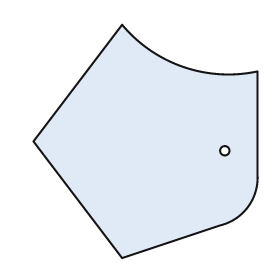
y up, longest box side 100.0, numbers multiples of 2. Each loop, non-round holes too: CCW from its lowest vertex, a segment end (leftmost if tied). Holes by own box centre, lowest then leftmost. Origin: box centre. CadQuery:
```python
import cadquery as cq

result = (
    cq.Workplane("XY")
    .moveTo(-10.0, -50.0)
    .lineTo(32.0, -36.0)
    .threePointArc((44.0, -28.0), (48.0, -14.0))
    .lineTo(48.0, 30.0)
    .threePointArc((16.0, 32.0), (-10.0, 50.0))
    .lineTo(-48.0, 0.0)
    .close()
    .moveTo(34.0, -4.0)
    .circle(2.0)
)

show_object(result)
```